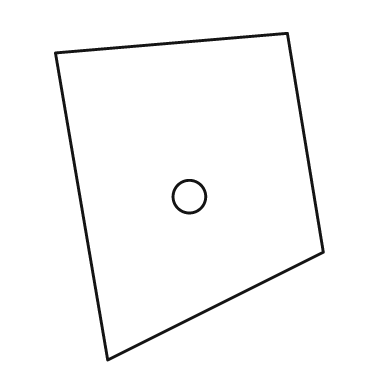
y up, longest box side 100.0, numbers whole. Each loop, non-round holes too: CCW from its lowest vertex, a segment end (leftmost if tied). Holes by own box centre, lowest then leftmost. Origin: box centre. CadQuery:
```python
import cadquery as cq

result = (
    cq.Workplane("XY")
    .moveTo(-25.0, -50.0)
    .lineTo(41.0, -17.0)
    .lineTo(30.0, 50.0)
    .lineTo(-41.0, 44.0)
    .close()
    .moveTo(0.0, 0.0)
    .circle(5.0)
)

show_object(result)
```